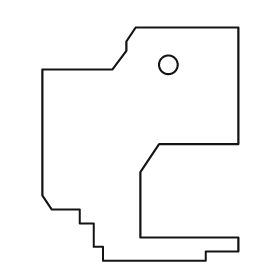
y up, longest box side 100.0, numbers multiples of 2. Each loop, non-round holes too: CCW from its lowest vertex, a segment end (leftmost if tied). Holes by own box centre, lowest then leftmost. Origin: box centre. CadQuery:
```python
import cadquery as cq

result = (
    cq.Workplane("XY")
    .moveTo(-16.0, -50.0)
    .lineTo(28.0, -50.0)
    .lineTo(28.0, -46.0)
    .lineTo(42.0, -46.0)
    .lineTo(42.0, -40.0)
    .lineTo(0.0, -40.0)
    .lineTo(0.0, -12.0)
    .lineTo(8.0, 0.0)
    .lineTo(42.0, 0.0)
    .lineTo(42.0, 50.0)
    .lineTo(-2.0, 50.0)
    .lineTo(-6.0, 44.0)
    .lineTo(-6.0, 40.0)
    .lineTo(-12.0, 32.0)
    .lineTo(-42.0, 32.0)
    .lineTo(-42.0, -22.0)
    .lineTo(-38.0, -28.0)
    .lineTo(-26.0, -28.0)
    .lineTo(-26.0, -34.0)
    .lineTo(-20.0, -34.0)
    .lineTo(-20.0, -44.0)
    .lineTo(-16.0, -44.0)
    .close()
    .moveTo(12.0, 34.0)
    .circle(4.0)
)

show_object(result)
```